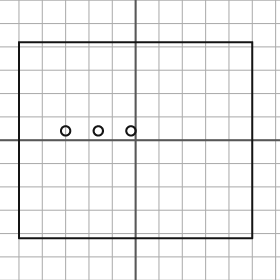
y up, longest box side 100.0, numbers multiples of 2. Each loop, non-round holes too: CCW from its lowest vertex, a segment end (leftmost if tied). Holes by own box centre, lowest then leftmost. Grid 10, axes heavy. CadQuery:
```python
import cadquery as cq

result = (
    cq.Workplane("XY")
    .moveTo(-50.0, -42.0)
    .lineTo(50.0, -42.0)
    .lineTo(50.0, 42.0)
    .lineTo(-50.0, 42.0)
    .close()
    .moveTo(-30.0, 4.0)
    .circle(2.0)
    .moveTo(-16.0, 4.0)
    .circle(2.0)
    .moveTo(-2.0, 4.0)
    .circle(2.0)
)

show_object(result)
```